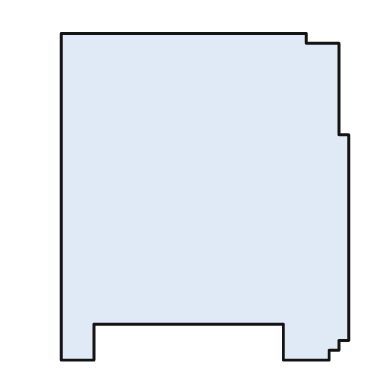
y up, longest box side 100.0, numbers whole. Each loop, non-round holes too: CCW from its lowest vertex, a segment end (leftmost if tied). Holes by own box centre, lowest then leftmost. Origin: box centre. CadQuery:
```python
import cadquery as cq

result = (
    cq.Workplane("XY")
    .moveTo(-44.0, -50.0)
    .lineTo(-34.0, -50.0)
    .lineTo(-34.0, -39.0)
    .lineTo(24.0, -39.0)
    .lineTo(24.0, -50.0)
    .lineTo(38.0, -50.0)
    .lineTo(38.0, -47.0)
    .lineTo(41.0, -47.0)
    .lineTo(41.0, -44.0)
    .lineTo(44.0, -44.0)
    .lineTo(44.0, 19.0)
    .lineTo(41.0, 19.0)
    .lineTo(41.0, 47.0)
    .lineTo(31.0, 47.0)
    .lineTo(31.0, 50.0)
    .lineTo(-44.0, 50.0)
    .close()
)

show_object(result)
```